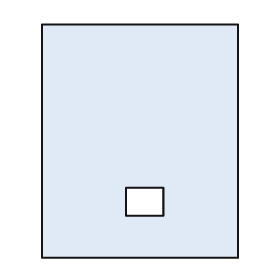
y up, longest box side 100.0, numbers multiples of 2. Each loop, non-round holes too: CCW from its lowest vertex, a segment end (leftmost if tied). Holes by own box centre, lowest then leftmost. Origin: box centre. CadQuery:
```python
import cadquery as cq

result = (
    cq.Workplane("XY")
    .moveTo(-42.0, -50.0)
    .lineTo(42.0, -50.0)
    .lineTo(42.0, 50.0)
    .lineTo(-42.0, 50.0)
    .close()
    .moveTo(-6.0, -32.0)
    .lineTo(10.0, -32.0)
    .lineTo(10.0, -20.0)
    .lineTo(-6.0, -20.0)
    .close()
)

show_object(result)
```